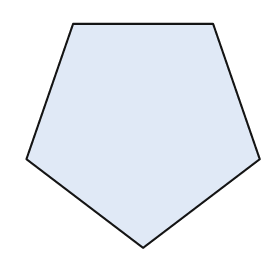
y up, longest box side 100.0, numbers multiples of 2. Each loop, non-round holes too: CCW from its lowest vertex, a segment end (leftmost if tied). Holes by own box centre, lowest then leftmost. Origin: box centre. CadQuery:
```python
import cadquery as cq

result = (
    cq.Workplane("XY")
    .moveTo(0.0, -48.0)
    .lineTo(50.0, -10.0)
    .lineTo(30.0, 48.0)
    .lineTo(-30.0, 48.0)
    .lineTo(-50.0, -10.0)
    .close()
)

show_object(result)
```